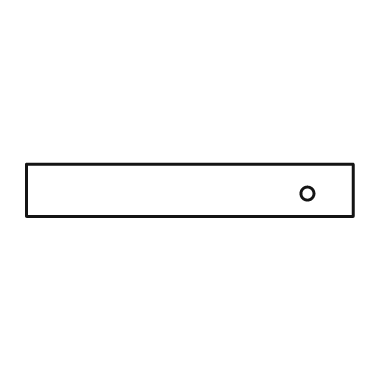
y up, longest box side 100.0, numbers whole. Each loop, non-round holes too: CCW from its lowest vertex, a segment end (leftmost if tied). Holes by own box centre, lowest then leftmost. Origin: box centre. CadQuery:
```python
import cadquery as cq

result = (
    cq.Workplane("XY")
    .moveTo(-50.0, -8.0)
    .lineTo(50.0, -8.0)
    .lineTo(50.0, 8.0)
    .lineTo(-50.0, 8.0)
    .close()
    .moveTo(36.0, -1.0)
    .circle(2.0)
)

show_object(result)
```